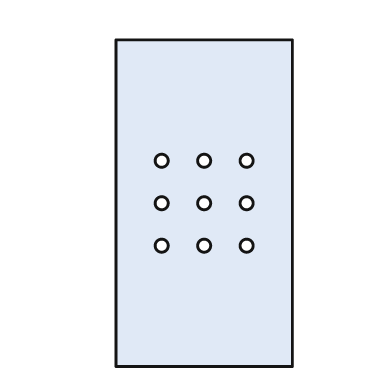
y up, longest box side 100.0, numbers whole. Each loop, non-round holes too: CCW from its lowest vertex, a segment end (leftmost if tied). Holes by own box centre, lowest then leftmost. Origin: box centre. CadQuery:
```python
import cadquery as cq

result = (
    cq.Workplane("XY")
    .moveTo(-27.0, -50.0)
    .lineTo(27.0, -50.0)
    .lineTo(27.0, 50.0)
    .lineTo(-27.0, 50.0)
    .close()
    .moveTo(-13.0, -13.0)
    .circle(2.0)
    .moveTo(0.0, -13.0)
    .circle(2.0)
    .moveTo(13.0, -13.0)
    .circle(2.0)
    .moveTo(-13.0, 0.0)
    .circle(2.0)
    .moveTo(0.0, 0.0)
    .circle(2.0)
    .moveTo(13.0, 0.0)
    .circle(2.0)
    .moveTo(-13.0, 13.0)
    .circle(2.0)
    .moveTo(0.0, 13.0)
    .circle(2.0)
    .moveTo(13.0, 13.0)
    .circle(2.0)
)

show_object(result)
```